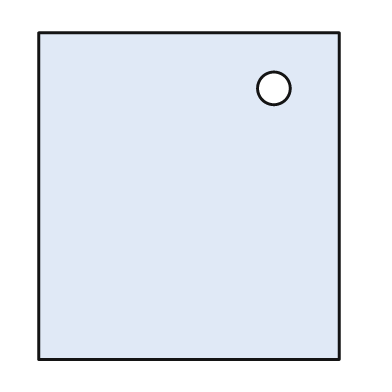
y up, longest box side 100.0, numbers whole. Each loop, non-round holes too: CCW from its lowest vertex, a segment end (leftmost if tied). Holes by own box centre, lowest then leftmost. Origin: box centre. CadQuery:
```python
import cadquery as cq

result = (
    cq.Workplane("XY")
    .moveTo(-46.0, -50.0)
    .lineTo(46.0, -50.0)
    .lineTo(46.0, 50.0)
    .lineTo(-46.0, 50.0)
    .close()
    .moveTo(26.0, 33.0)
    .circle(5.0)
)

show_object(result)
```